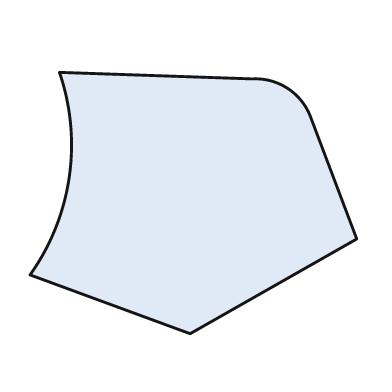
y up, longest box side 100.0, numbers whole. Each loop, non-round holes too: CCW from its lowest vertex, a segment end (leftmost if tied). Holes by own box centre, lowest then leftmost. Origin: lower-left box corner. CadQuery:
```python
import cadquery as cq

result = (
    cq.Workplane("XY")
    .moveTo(49.0, 0.0)
    .lineTo(100.0, 29.0)
    .lineTo(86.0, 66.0)
    .threePointArc((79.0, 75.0), (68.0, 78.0))
    .lineTo(9.0, 80.0)
    .threePointArc((12.0, 48.0), (0.0, 18.0))
    .close()
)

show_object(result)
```